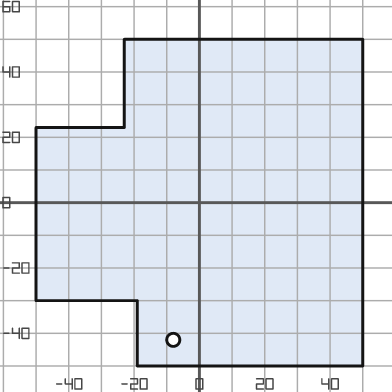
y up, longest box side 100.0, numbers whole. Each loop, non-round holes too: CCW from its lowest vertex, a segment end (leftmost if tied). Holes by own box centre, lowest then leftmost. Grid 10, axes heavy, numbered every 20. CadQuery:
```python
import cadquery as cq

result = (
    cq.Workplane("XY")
    .moveTo(-19.0, -50.0)
    .lineTo(50.0, -50.0)
    .lineTo(50.0, 50.0)
    .lineTo(-23.0, 50.0)
    .lineTo(-23.0, 23.0)
    .lineTo(-50.0, 23.0)
    .lineTo(-50.0, -30.0)
    .lineTo(-19.0, -30.0)
    .close()
    .moveTo(-8.0, -42.0)
    .circle(2.0)
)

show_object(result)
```